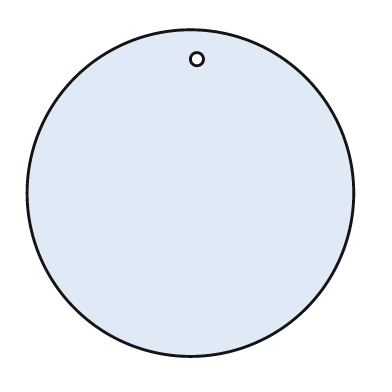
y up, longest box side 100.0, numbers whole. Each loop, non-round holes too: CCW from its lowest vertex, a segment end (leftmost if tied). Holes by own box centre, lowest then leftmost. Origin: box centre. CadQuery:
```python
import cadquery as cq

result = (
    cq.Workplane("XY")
    .moveTo(0.0, 0.0)
    .circle(50.0)
    .moveTo(2.0, 41.0)
    .circle(2.0)
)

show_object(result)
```